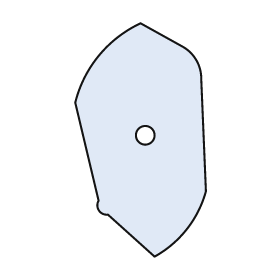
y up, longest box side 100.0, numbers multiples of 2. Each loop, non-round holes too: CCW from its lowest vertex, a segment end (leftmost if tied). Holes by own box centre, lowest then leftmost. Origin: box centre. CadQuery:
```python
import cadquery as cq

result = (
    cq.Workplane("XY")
    .moveTo(6.0, -50.0)
    .threePointArc((20.0, -38.0), (28.0, -22.0))
    .lineTo(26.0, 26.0)
    .threePointArc((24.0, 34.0), (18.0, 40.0))
    .lineTo(0.0, 50.0)
    .threePointArc((-18.0, 36.0), (-28.0, 16.0))
    .lineTo(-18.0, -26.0)
    .threePointArc((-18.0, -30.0), (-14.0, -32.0))
    .close()
    .moveTo(2.0, 2.0)
    .circle(4.0)
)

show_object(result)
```